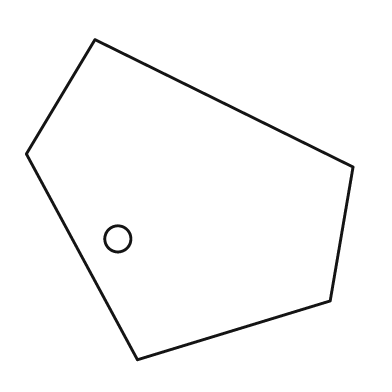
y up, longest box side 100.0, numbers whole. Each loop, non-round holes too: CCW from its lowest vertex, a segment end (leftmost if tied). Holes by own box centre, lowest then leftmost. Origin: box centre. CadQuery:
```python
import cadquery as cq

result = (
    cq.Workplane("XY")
    .moveTo(-16.0, -49.0)
    .lineTo(43.0, -31.0)
    .lineTo(50.0, 10.0)
    .lineTo(-29.0, 49.0)
    .lineTo(-50.0, 14.0)
    .close()
    .moveTo(-22.0, -12.0)
    .circle(4.0)
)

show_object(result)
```